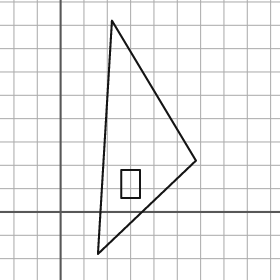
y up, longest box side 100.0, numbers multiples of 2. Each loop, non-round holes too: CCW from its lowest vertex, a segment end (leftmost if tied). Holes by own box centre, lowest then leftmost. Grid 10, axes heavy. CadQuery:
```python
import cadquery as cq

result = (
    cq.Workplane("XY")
    .moveTo(16.0, -18.0)
    .lineTo(58.0, 22.0)
    .lineTo(22.0, 82.0)
    .close()
    .moveTo(26.0, 6.0)
    .lineTo(34.0, 6.0)
    .lineTo(34.0, 18.0)
    .lineTo(26.0, 18.0)
    .close()
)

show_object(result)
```